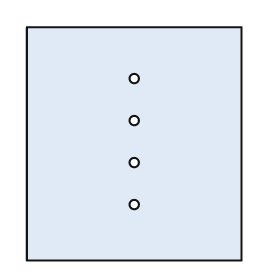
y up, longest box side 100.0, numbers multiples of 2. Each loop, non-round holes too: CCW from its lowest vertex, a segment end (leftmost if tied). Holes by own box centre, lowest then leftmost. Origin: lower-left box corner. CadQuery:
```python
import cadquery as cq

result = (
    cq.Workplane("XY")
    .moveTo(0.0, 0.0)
    .lineTo(92.0, 0.0)
    .lineTo(92.0, 100.0)
    .lineTo(0.0, 100.0)
    .close()
    .moveTo(46.0, 24.0)
    .circle(2.0)
    .moveTo(46.0, 42.0)
    .circle(2.0)
    .moveTo(46.0, 60.0)
    .circle(2.0)
    .moveTo(46.0, 78.0)
    .circle(2.0)
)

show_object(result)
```